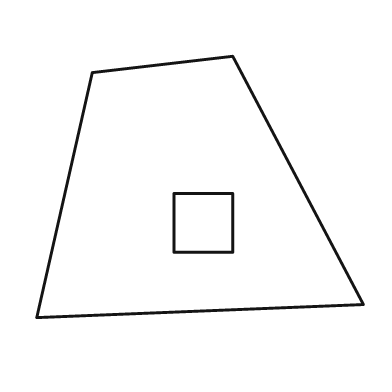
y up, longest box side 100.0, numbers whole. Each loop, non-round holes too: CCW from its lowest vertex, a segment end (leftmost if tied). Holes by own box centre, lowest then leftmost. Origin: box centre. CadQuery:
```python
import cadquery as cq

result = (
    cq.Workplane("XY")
    .moveTo(-50.0, -40.0)
    .lineTo(50.0, -36.0)
    .lineTo(10.0, 40.0)
    .lineTo(-33.0, 35.0)
    .close()
    .moveTo(-8.0, -20.0)
    .lineTo(10.0, -20.0)
    .lineTo(10.0, -2.0)
    .lineTo(-8.0, -2.0)
    .close()
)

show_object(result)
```